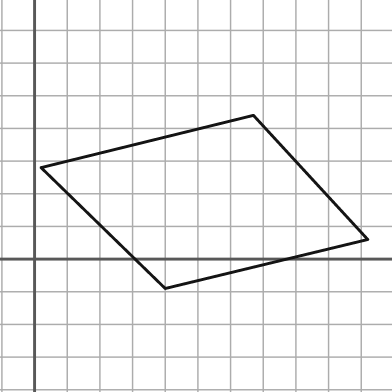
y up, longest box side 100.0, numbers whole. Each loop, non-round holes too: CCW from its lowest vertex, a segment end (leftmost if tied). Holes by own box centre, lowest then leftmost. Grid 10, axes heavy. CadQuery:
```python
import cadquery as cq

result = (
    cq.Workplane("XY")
    .moveTo(40.0, -9.0)
    .lineTo(102.0, 6.0)
    .lineTo(67.0, 44.0)
    .lineTo(2.0, 28.0)
    .close()
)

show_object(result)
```